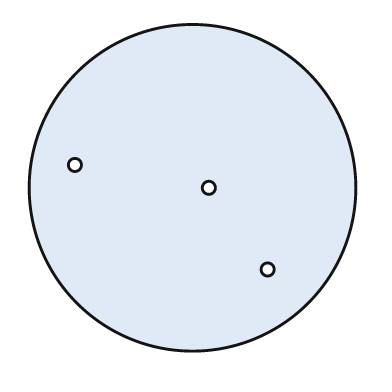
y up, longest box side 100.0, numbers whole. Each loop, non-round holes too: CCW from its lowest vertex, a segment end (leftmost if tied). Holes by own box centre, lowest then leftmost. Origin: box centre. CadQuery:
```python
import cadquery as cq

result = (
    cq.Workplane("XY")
    .moveTo(0.0, 0.0)
    .circle(50.0)
    .moveTo(23.0, -25.0)
    .circle(2.0)
    .moveTo(5.0, 0.0)
    .circle(2.0)
    .moveTo(-36.0, 7.0)
    .circle(2.0)
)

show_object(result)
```